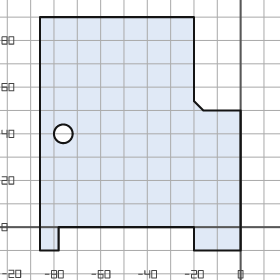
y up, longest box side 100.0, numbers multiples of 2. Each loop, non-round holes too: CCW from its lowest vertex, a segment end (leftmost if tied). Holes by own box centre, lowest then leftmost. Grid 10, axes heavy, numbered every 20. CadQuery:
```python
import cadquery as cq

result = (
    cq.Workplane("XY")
    .moveTo(-86.0, -10.0)
    .lineTo(-78.0, -10.0)
    .lineTo(-78.0, 0.0)
    .lineTo(-20.0, 0.0)
    .lineTo(-20.0, -10.0)
    .lineTo(0.0, -10.0)
    .lineTo(0.0, 50.0)
    .lineTo(-16.0, 50.0)
    .lineTo(-20.0, 54.0)
    .lineTo(-20.0, 90.0)
    .lineTo(-86.0, 90.0)
    .close()
    .moveTo(-76.0, 40.0)
    .circle(4.0)
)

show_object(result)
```